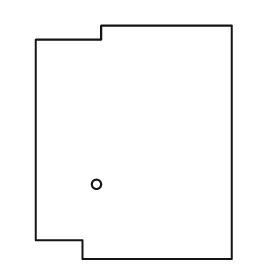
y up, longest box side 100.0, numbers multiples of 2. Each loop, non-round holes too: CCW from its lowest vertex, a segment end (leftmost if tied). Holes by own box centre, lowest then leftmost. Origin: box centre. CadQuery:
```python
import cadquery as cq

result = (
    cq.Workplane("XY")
    .moveTo(-22.0, -50.0)
    .lineTo(42.0, -50.0)
    .lineTo(42.0, 50.0)
    .lineTo(-14.0, 50.0)
    .lineTo(-14.0, 44.0)
    .lineTo(-42.0, 44.0)
    .lineTo(-42.0, -42.0)
    .lineTo(-22.0, -42.0)
    .close()
    .moveTo(-16.0, -18.0)
    .circle(2.0)
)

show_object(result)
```